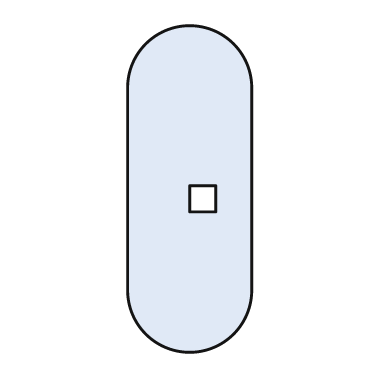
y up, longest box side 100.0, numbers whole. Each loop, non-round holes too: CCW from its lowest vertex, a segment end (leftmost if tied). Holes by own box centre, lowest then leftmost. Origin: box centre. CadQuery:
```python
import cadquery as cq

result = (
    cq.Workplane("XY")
    .moveTo(-19.0, -31.0)
    .threePointArc((0.0, -50.0), (19.0, -31.0))
    .lineTo(19.0, 31.0)
    .threePointArc((0.0, 50.0), (-19.0, 31.0))
    .close()
    .moveTo(0.0, -7.0)
    .lineTo(8.0, -7.0)
    .lineTo(8.0, 1.0)
    .lineTo(0.0, 1.0)
    .close()
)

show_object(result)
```